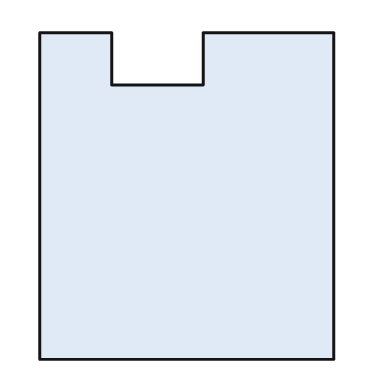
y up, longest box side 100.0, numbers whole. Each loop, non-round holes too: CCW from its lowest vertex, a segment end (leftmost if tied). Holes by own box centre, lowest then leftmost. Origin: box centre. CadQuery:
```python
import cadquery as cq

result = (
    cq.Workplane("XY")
    .moveTo(-45.0, -50.0)
    .lineTo(45.0, -50.0)
    .lineTo(45.0, 50.0)
    .lineTo(5.0, 50.0)
    .lineTo(5.0, 34.0)
    .lineTo(-23.0, 34.0)
    .lineTo(-23.0, 50.0)
    .lineTo(-45.0, 50.0)
    .close()
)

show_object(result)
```